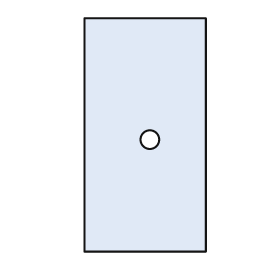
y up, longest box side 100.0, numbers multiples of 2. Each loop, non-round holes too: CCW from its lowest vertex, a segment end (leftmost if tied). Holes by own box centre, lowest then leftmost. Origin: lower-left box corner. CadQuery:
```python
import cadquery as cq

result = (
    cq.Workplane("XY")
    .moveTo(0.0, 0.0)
    .lineTo(52.0, 0.0)
    .lineTo(52.0, 100.0)
    .lineTo(0.0, 100.0)
    .close()
    .moveTo(28.0, 48.0)
    .circle(4.0)
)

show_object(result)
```